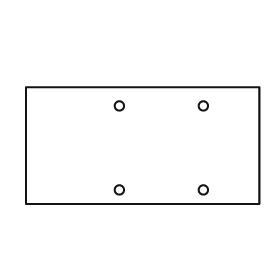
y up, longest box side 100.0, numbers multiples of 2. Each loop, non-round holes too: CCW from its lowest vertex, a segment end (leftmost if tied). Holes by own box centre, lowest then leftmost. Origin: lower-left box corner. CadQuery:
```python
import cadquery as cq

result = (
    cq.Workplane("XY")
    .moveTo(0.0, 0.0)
    .lineTo(100.0, 0.0)
    .lineTo(100.0, 50.0)
    .lineTo(0.0, 50.0)
    .close()
    .moveTo(40.0, 6.0)
    .circle(2.0)
    .moveTo(76.0, 6.0)
    .circle(2.0)
    .moveTo(40.0, 42.0)
    .circle(2.0)
    .moveTo(76.0, 42.0)
    .circle(2.0)
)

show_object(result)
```